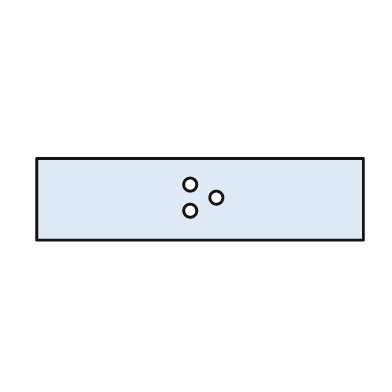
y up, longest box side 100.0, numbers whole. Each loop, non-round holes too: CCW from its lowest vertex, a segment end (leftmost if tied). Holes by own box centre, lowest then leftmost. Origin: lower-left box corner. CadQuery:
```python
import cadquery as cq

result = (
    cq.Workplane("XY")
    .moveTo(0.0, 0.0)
    .lineTo(100.0, 0.0)
    .lineTo(100.0, 25.0)
    .lineTo(0.0, 25.0)
    .close()
    .moveTo(47.0, 9.0)
    .circle(2.0)
    .moveTo(55.0, 13.0)
    .circle(2.0)
    .moveTo(47.0, 17.0)
    .circle(2.0)
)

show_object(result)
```